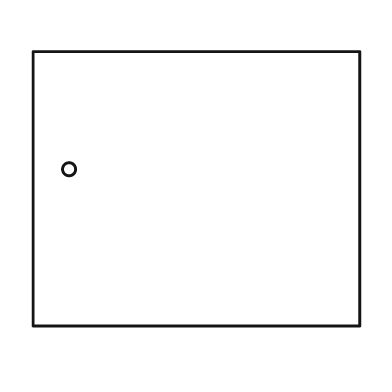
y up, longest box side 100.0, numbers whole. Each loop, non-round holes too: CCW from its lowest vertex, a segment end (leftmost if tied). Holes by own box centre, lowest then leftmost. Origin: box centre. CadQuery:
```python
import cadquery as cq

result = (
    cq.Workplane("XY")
    .moveTo(-50.0, -42.0)
    .lineTo(50.0, -42.0)
    .lineTo(50.0, 42.0)
    .lineTo(-50.0, 42.0)
    .close()
    .moveTo(-39.0, 6.0)
    .circle(2.0)
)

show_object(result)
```